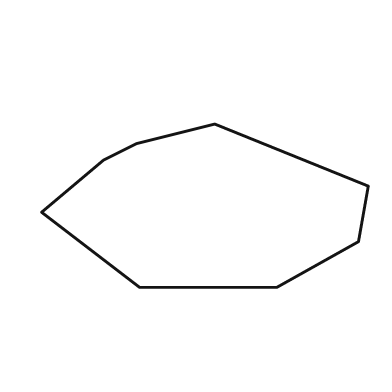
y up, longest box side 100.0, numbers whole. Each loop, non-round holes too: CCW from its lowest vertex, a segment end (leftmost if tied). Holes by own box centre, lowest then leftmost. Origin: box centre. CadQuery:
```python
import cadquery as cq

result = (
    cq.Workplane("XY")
    .moveTo(-20.0, -25.0)
    .lineTo(22.0, -25.0)
    .lineTo(47.0, -11.0)
    .lineTo(50.0, 6.0)
    .lineTo(3.0, 25.0)
    .lineTo(-21.0, 19.0)
    .lineTo(-31.0, 14.0)
    .lineTo(-50.0, -2.0)
    .close()
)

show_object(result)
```